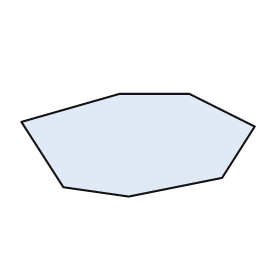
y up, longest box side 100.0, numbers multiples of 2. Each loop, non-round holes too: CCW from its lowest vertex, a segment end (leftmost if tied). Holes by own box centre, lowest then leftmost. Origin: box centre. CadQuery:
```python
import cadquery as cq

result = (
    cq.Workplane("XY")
    .moveTo(-4.0, -22.0)
    .lineTo(36.0, -14.0)
    .lineTo(50.0, 8.0)
    .lineTo(22.0, 22.0)
    .lineTo(-8.0, 22.0)
    .lineTo(-50.0, 10.0)
    .lineTo(-32.0, -18.0)
    .close()
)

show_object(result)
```